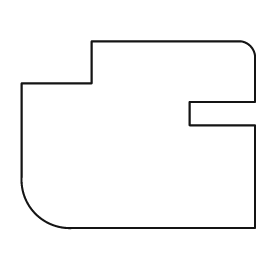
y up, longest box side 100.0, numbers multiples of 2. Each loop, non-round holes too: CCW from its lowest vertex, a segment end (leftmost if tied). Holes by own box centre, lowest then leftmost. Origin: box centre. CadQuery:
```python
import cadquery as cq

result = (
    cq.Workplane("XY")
    .moveTo(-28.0, -40.0)
    .lineTo(50.0, -40.0)
    .lineTo(50.0, 4.0)
    .lineTo(22.0, 4.0)
    .lineTo(22.0, 14.0)
    .lineTo(50.0, 14.0)
    .lineTo(50.0, 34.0)
    .threePointArc((48.0, 38.0), (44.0, 40.0))
    .lineTo(-20.0, 40.0)
    .lineTo(-20.0, 22.0)
    .lineTo(-50.0, 22.0)
    .lineTo(-50.0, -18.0)
    .threePointArc((-44.0, -34.0), (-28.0, -40.0))
    .close()
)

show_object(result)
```